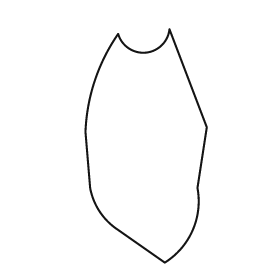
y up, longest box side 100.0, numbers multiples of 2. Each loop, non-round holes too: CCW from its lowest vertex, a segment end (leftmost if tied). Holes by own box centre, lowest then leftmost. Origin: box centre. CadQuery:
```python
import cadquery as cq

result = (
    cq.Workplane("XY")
    .moveTo(8.0, -50.0)
    .threePointArc((20.0, -36.0), (22.0, -18.0))
    .lineTo(26.0, 8.0)
    .lineTo(10.0, 50.0)
    .threePointArc((0.0, 40.0), (-12.0, 48.0))
    .threePointArc((-22.0, 28.0), (-26.0, 6.0))
    .lineTo(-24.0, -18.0)
    .threePointArc((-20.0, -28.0), (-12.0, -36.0))
    .close()
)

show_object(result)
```